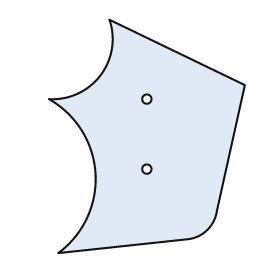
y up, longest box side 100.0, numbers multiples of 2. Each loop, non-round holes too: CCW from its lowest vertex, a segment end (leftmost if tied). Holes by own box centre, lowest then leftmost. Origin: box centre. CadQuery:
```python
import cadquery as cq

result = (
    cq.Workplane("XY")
    .moveTo(-38.0, -50.0)
    .lineTo(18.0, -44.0)
    .threePointArc((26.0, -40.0), (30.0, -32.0))
    .lineTo(42.0, 22.0)
    .lineTo(-16.0, 50.0)
    .threePointArc((-20.0, 26.0), (-42.0, 16.0))
    .threePointArc((-22.0, -16.0), (-38.0, -50.0))
    .close()
    .moveTo(0.0, -14.0)
    .circle(2.0)
    .moveTo(0.0, 16.0)
    .circle(2.0)
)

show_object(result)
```